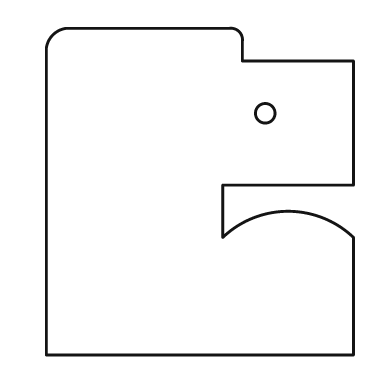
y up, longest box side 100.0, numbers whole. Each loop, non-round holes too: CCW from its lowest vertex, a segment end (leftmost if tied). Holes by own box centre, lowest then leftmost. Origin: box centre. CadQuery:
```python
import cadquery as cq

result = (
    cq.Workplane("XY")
    .moveTo(-47.0, -50.0)
    .lineTo(47.0, -50.0)
    .lineTo(47.0, -14.0)
    .threePointArc((27.0, -6.0), (7.0, -14.0))
    .lineTo(7.0, 2.0)
    .lineTo(47.0, 2.0)
    .lineTo(47.0, 40.0)
    .lineTo(13.0, 40.0)
    .lineTo(13.0, 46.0)
    .threePointArc((12.0, 49.0), (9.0, 50.0))
    .lineTo(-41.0, 50.0)
    .threePointArc((-45.0, 48.0), (-47.0, 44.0))
    .close()
    .moveTo(20.0, 24.0)
    .circle(3.0)
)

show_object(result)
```